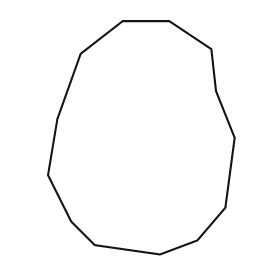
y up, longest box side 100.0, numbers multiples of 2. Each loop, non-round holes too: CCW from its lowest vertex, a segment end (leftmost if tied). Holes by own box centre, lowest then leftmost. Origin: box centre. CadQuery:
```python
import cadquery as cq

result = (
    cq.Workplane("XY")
    .moveTo(8.0, -50.0)
    .lineTo(24.0, -44.0)
    .lineTo(36.0, -30.0)
    .lineTo(40.0, 0.0)
    .lineTo(32.0, 20.0)
    .lineTo(30.0, 38.0)
    .lineTo(12.0, 50.0)
    .lineTo(-8.0, 50.0)
    .lineTo(-26.0, 36.0)
    .lineTo(-36.0, 8.0)
    .lineTo(-40.0, -16.0)
    .lineTo(-30.0, -36.0)
    .lineTo(-20.0, -46.0)
    .close()
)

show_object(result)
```